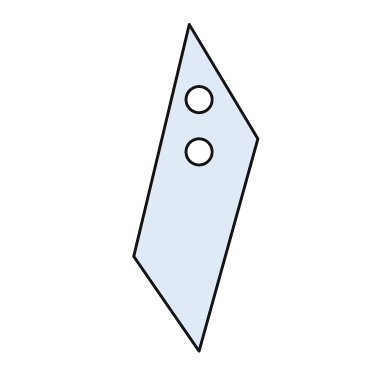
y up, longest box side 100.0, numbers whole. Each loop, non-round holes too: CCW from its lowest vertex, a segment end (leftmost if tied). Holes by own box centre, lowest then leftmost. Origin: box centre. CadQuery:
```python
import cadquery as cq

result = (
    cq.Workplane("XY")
    .moveTo(1.0, -50.0)
    .lineTo(19.0, 15.0)
    .lineTo(-2.0, 50.0)
    .lineTo(-19.0, -21.0)
    .close()
    .moveTo(1.0, 11.0)
    .circle(4.0)
    .moveTo(1.0, 27.0)
    .circle(4.0)
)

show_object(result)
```